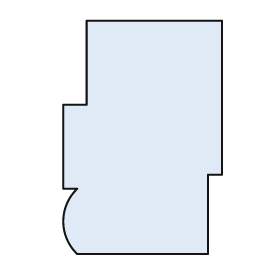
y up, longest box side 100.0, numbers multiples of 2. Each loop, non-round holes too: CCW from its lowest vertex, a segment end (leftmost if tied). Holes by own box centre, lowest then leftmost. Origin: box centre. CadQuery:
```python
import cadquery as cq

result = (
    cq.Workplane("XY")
    .moveTo(-28.0, -50.0)
    .lineTo(28.0, -50.0)
    .lineTo(28.0, -16.0)
    .lineTo(34.0, -16.0)
    .lineTo(34.0, 50.0)
    .lineTo(-24.0, 50.0)
    .lineTo(-24.0, 14.0)
    .lineTo(-34.0, 14.0)
    .lineTo(-34.0, -22.0)
    .lineTo(-28.0, -22.0)
    .threePointArc((-34.0, -36.0), (-28.0, -50.0))
    .close()
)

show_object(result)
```